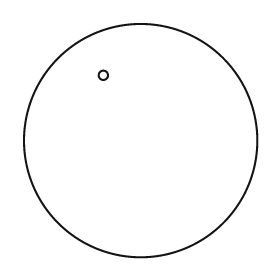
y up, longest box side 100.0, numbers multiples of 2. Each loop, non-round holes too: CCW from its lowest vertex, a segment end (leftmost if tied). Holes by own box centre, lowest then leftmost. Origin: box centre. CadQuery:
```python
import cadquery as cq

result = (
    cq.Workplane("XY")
    .moveTo(0.0, 0.0)
    .circle(50.0)
    .moveTo(-16.0, 28.0)
    .circle(2.0)
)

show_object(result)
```